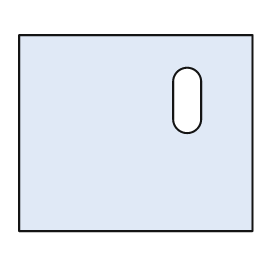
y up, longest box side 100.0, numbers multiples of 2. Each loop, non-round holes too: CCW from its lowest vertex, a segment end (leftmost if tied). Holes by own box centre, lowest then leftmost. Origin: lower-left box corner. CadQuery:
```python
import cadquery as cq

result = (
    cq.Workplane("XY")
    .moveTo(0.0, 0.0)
    .lineTo(100.0, 0.0)
    .lineTo(100.0, 84.0)
    .lineTo(0.0, 84.0)
    .close()
    .moveTo(66.0, 48.0)
    .threePointArc((72.0, 42.0), (78.0, 48.0))
    .lineTo(78.0, 64.0)
    .threePointArc((72.0, 70.0), (66.0, 64.0))
    .close()
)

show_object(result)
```